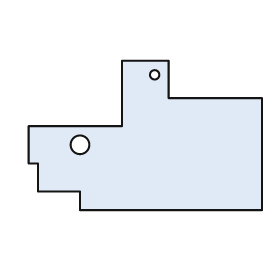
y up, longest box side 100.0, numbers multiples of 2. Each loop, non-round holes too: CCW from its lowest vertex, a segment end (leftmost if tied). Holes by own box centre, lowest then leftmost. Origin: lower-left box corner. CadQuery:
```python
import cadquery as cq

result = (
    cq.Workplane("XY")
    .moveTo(22.0, 0.0)
    .lineTo(100.0, 0.0)
    .lineTo(100.0, 48.0)
    .lineTo(60.0, 48.0)
    .lineTo(60.0, 64.0)
    .lineTo(40.0, 64.0)
    .lineTo(40.0, 36.0)
    .lineTo(0.0, 36.0)
    .lineTo(0.0, 20.0)
    .lineTo(4.0, 20.0)
    .lineTo(4.0, 8.0)
    .lineTo(22.0, 8.0)
    .close()
    .moveTo(22.0, 28.0)
    .circle(4.0)
    .moveTo(54.0, 58.0)
    .circle(2.0)
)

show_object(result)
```